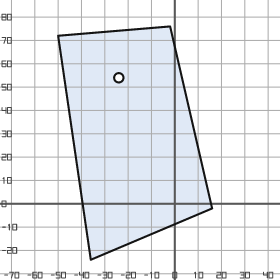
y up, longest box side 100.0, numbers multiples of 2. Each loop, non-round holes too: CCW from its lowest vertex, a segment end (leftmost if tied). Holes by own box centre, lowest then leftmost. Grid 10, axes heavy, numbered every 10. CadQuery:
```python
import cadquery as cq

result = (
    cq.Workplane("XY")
    .moveTo(-36.0, -24.0)
    .lineTo(16.0, -2.0)
    .lineTo(-2.0, 76.0)
    .lineTo(-50.0, 72.0)
    .close()
    .moveTo(-24.0, 54.0)
    .circle(2.0)
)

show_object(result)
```